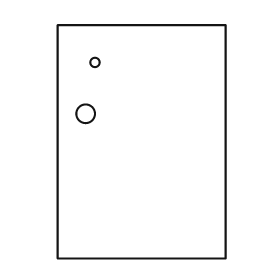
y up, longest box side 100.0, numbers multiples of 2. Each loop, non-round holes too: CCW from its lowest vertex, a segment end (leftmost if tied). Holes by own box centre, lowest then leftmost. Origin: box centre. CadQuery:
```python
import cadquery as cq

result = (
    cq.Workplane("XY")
    .moveTo(-36.0, -50.0)
    .lineTo(36.0, -50.0)
    .lineTo(36.0, 50.0)
    .lineTo(-36.0, 50.0)
    .close()
    .moveTo(-24.0, 12.0)
    .circle(4.0)
    .moveTo(-20.0, 34.0)
    .circle(2.0)
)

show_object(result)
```